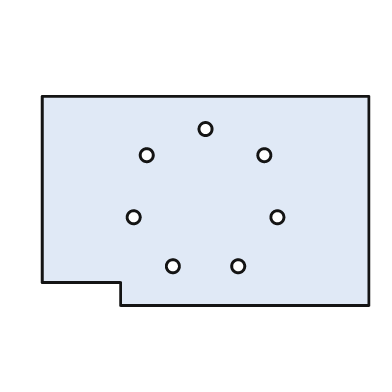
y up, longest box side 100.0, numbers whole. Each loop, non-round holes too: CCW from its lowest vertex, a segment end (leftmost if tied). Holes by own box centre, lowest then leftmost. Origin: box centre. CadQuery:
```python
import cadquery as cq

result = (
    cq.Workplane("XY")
    .moveTo(-26.0, -32.0)
    .lineTo(50.0, -32.0)
    .lineTo(50.0, 32.0)
    .lineTo(-50.0, 32.0)
    .lineTo(-50.0, -25.0)
    .lineTo(-26.0, -25.0)
    .close()
    .moveTo(-10.0, -20.0)
    .circle(2.0)
    .moveTo(10.0, -20.0)
    .circle(2.0)
    .moveTo(-22.0, -5.0)
    .circle(2.0)
    .moveTo(22.0, -5.0)
    .circle(2.0)
    .moveTo(-18.0, 14.0)
    .circle(2.0)
    .moveTo(18.0, 14.0)
    .circle(2.0)
    .moveTo(0.0, 22.0)
    .circle(2.0)
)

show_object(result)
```